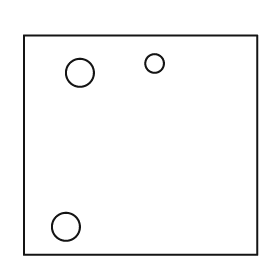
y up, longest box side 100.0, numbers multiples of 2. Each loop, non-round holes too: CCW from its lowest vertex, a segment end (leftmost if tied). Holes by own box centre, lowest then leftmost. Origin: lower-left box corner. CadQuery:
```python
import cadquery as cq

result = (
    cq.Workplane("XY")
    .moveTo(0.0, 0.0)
    .lineTo(100.0, 0.0)
    .lineTo(100.0, 94.0)
    .lineTo(0.0, 94.0)
    .close()
    .moveTo(18.0, 12.0)
    .circle(6.0)
    .moveTo(24.0, 78.0)
    .circle(6.0)
    .moveTo(56.0, 82.0)
    .circle(4.0)
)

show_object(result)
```